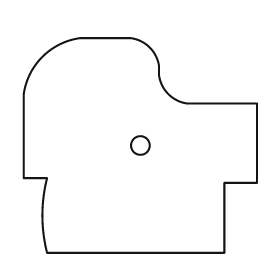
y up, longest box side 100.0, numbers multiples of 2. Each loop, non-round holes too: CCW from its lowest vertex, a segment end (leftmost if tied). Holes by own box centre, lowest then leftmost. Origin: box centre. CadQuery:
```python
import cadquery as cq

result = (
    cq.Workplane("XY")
    .moveTo(-40.0, -46.0)
    .lineTo(36.0, -46.0)
    .lineTo(36.0, -16.0)
    .lineTo(50.0, -16.0)
    .lineTo(50.0, 18.0)
    .lineTo(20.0, 18.0)
    .threePointArc((12.0, 22.0), (8.0, 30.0))
    .lineTo(8.0, 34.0)
    .threePointArc((4.0, 42.0), (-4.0, 46.0))
    .lineTo(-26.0, 46.0)
    .threePointArc((-42.0, 38.0), (-50.0, 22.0))
    .lineTo(-50.0, -14.0)
    .lineTo(-40.0, -14.0)
    .threePointArc((-42.0, -30.0), (-40.0, -46.0))
    .close()
    .moveTo(0.0, 0.0)
    .circle(4.0)
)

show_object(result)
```